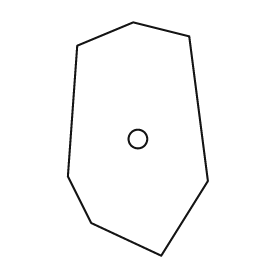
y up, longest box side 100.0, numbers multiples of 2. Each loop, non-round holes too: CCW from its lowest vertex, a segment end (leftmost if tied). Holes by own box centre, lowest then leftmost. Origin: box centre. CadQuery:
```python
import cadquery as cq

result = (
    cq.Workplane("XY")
    .moveTo(10.0, -50.0)
    .lineTo(30.0, -18.0)
    .lineTo(22.0, 44.0)
    .lineTo(-2.0, 50.0)
    .lineTo(-26.0, 40.0)
    .lineTo(-30.0, -16.0)
    .lineTo(-20.0, -36.0)
    .close()
    .moveTo(0.0, 0.0)
    .circle(4.0)
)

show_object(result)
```